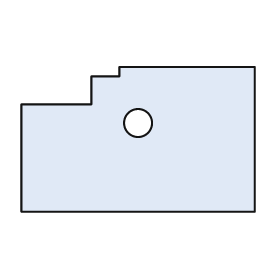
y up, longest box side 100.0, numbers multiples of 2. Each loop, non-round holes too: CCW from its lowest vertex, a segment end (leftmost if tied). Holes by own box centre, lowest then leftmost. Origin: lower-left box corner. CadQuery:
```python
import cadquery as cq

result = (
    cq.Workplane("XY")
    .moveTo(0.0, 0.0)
    .lineTo(100.0, 0.0)
    .lineTo(100.0, 62.0)
    .lineTo(42.0, 62.0)
    .lineTo(42.0, 58.0)
    .lineTo(30.0, 58.0)
    .lineTo(30.0, 46.0)
    .lineTo(0.0, 46.0)
    .close()
    .moveTo(50.0, 38.0)
    .circle(6.0)
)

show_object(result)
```